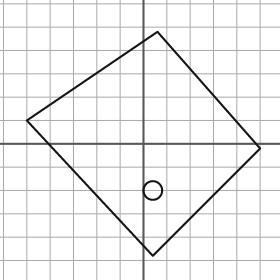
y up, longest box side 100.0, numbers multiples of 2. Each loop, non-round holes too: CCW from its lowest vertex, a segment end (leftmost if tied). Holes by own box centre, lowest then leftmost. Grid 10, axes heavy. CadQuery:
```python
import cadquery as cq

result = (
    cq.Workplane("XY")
    .moveTo(4.0, -48.0)
    .lineTo(50.0, -2.0)
    .lineTo(6.0, 48.0)
    .lineTo(-50.0, 10.0)
    .close()
    .moveTo(4.0, -20.0)
    .circle(4.0)
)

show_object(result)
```